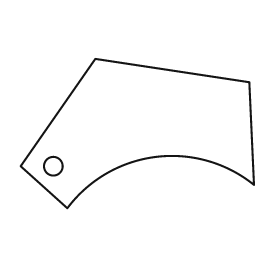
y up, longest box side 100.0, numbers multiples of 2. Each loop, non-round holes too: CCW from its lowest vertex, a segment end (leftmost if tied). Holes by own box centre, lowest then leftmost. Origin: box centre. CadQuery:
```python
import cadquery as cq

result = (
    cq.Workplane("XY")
    .moveTo(-30.0, -32.0)
    .threePointArc((8.0, -10.0), (50.0, -22.0))
    .lineTo(48.0, 22.0)
    .lineTo(-18.0, 32.0)
    .lineTo(-50.0, -14.0)
    .close()
    .moveTo(-36.0, -14.0)
    .circle(4.0)
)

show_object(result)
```